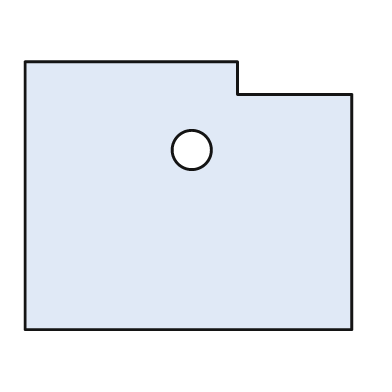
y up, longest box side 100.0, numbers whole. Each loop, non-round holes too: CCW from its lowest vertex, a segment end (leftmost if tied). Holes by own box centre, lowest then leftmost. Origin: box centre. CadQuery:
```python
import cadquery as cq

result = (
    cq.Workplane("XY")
    .moveTo(-50.0, -41.0)
    .lineTo(50.0, -41.0)
    .lineTo(50.0, 31.0)
    .lineTo(15.0, 31.0)
    .lineTo(15.0, 41.0)
    .lineTo(-50.0, 41.0)
    .close()
    .moveTo(1.0, 14.0)
    .circle(6.0)
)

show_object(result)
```